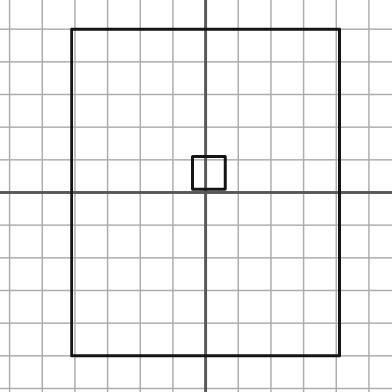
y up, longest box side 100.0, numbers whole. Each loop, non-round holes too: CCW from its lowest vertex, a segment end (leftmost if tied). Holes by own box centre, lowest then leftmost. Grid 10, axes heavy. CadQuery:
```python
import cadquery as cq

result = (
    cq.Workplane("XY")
    .moveTo(-41.0, -50.0)
    .lineTo(41.0, -50.0)
    .lineTo(41.0, 50.0)
    .lineTo(-41.0, 50.0)
    .close()
    .moveTo(-4.0, 1.0)
    .lineTo(6.0, 1.0)
    .lineTo(6.0, 11.0)
    .lineTo(-4.0, 11.0)
    .close()
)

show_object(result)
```